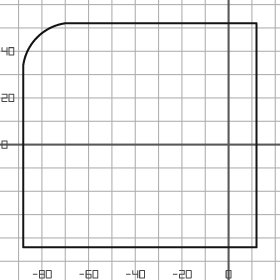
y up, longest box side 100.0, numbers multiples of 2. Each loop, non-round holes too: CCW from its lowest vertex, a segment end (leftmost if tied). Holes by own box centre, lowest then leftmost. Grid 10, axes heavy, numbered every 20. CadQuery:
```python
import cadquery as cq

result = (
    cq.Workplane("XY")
    .moveTo(-88.0, -44.0)
    .lineTo(12.0, -44.0)
    .lineTo(12.0, 52.0)
    .lineTo(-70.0, 52.0)
    .threePointArc((-82.0, 46.0), (-88.0, 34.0))
    .close()
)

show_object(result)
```